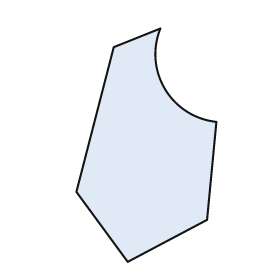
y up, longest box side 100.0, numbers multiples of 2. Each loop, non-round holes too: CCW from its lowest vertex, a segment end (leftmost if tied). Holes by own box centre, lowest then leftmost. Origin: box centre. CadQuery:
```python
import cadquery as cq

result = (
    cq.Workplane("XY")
    .moveTo(-8.0, -50.0)
    .lineTo(26.0, -32.0)
    .lineTo(30.0, 10.0)
    .threePointArc((8.0, 24.0), (6.0, 50.0))
    .lineTo(-14.0, 42.0)
    .lineTo(-30.0, -20.0)
    .close()
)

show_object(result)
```